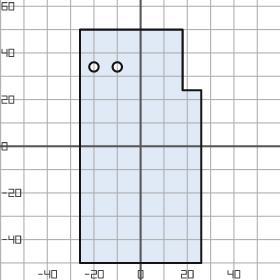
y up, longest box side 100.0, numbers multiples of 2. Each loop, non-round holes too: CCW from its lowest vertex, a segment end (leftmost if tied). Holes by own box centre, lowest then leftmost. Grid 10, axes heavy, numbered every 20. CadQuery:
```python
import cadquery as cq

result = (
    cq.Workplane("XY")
    .moveTo(-26.0, -50.0)
    .lineTo(26.0, -50.0)
    .lineTo(26.0, 24.0)
    .lineTo(18.0, 24.0)
    .lineTo(18.0, 50.0)
    .lineTo(-26.0, 50.0)
    .close()
    .moveTo(-20.0, 34.0)
    .circle(2.0)
    .moveTo(-10.0, 34.0)
    .circle(2.0)
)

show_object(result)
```